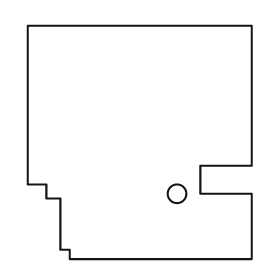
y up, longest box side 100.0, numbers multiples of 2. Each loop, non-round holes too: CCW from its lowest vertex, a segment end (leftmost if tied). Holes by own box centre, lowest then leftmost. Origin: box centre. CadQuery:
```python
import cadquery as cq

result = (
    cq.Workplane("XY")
    .moveTo(-30.0, -50.0)
    .lineTo(48.0, -50.0)
    .lineTo(48.0, -22.0)
    .lineTo(26.0, -22.0)
    .lineTo(26.0, -10.0)
    .lineTo(48.0, -10.0)
    .lineTo(48.0, 50.0)
    .lineTo(-48.0, 50.0)
    .lineTo(-48.0, -18.0)
    .lineTo(-40.0, -18.0)
    .lineTo(-40.0, -24.0)
    .lineTo(-34.0, -24.0)
    .lineTo(-34.0, -46.0)
    .lineTo(-30.0, -46.0)
    .close()
    .moveTo(16.0, -22.0)
    .circle(4.0)
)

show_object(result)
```